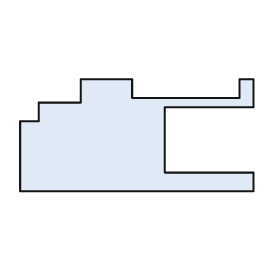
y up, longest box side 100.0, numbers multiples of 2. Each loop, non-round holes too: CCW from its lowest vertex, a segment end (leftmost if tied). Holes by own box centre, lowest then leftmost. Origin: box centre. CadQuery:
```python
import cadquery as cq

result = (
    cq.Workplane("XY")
    .moveTo(-50.0, -24.0)
    .lineTo(50.0, -24.0)
    .lineTo(50.0, -16.0)
    .lineTo(12.0, -16.0)
    .lineTo(12.0, 12.0)
    .lineTo(50.0, 12.0)
    .lineTo(50.0, 24.0)
    .lineTo(44.0, 24.0)
    .lineTo(44.0, 16.0)
    .lineTo(-2.0, 16.0)
    .lineTo(-2.0, 24.0)
    .lineTo(-24.0, 24.0)
    .lineTo(-24.0, 14.0)
    .lineTo(-42.0, 14.0)
    .lineTo(-42.0, 6.0)
    .lineTo(-50.0, 6.0)
    .close()
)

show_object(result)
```